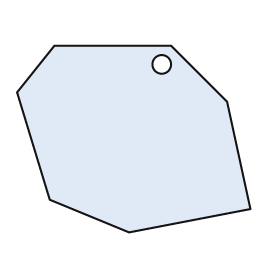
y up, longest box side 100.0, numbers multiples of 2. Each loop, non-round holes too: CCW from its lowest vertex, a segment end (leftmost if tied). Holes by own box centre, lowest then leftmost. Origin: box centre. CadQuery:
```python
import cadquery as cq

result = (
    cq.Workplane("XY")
    .moveTo(-2.0, -40.0)
    .lineTo(50.0, -30.0)
    .lineTo(40.0, 16.0)
    .lineTo(16.0, 40.0)
    .lineTo(-34.0, 40.0)
    .lineTo(-50.0, 20.0)
    .lineTo(-36.0, -26.0)
    .close()
    .moveTo(12.0, 32.0)
    .circle(4.0)
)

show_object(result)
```